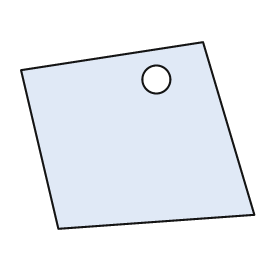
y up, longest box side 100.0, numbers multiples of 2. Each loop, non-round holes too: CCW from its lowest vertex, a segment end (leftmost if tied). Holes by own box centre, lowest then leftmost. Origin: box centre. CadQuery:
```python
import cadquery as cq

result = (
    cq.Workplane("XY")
    .moveTo(-34.0, -40.0)
    .lineTo(50.0, -34.0)
    .lineTo(28.0, 40.0)
    .lineTo(-50.0, 28.0)
    .close()
    .moveTo(8.0, 24.0)
    .circle(6.0)
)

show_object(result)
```